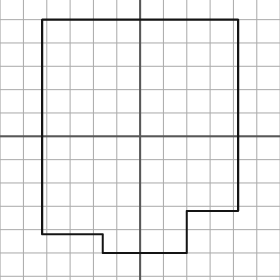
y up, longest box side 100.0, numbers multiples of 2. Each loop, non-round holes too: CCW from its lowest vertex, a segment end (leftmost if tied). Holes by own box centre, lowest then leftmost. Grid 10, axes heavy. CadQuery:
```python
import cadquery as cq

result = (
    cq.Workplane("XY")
    .moveTo(-16.0, -50.0)
    .lineTo(20.0, -50.0)
    .lineTo(20.0, -32.0)
    .lineTo(42.0, -32.0)
    .lineTo(42.0, 50.0)
    .lineTo(-42.0, 50.0)
    .lineTo(-42.0, -42.0)
    .lineTo(-16.0, -42.0)
    .close()
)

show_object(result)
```